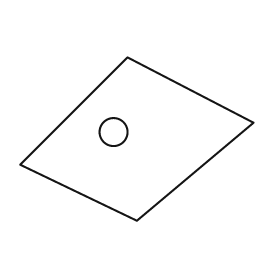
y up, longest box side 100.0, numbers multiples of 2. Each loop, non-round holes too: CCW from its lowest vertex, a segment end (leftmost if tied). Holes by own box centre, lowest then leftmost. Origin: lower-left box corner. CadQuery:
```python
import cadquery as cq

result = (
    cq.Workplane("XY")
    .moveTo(50.0, 0.0)
    .lineTo(100.0, 42.0)
    .lineTo(46.0, 70.0)
    .lineTo(0.0, 24.0)
    .close()
    .moveTo(40.0, 38.0)
    .circle(6.0)
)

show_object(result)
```